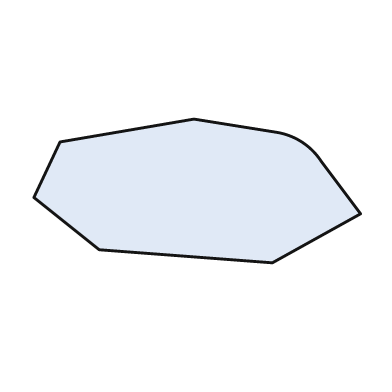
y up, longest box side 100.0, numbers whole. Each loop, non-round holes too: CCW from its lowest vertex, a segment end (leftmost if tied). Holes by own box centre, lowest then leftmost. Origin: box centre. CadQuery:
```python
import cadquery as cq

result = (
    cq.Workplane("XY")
    .moveTo(23.0, -22.0)
    .lineTo(50.0, -7.0)
    .lineTo(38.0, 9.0)
    .threePointArc((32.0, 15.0), (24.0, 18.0))
    .lineTo(-1.0, 22.0)
    .lineTo(-42.0, 15.0)
    .lineTo(-50.0, -2.0)
    .lineTo(-30.0, -18.0)
    .close()
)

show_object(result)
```